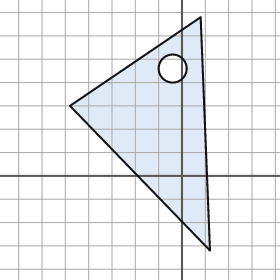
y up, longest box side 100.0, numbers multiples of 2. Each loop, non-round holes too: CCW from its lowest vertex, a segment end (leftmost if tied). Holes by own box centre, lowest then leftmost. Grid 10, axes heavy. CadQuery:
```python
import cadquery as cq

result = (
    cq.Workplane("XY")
    .moveTo(12.0, -32.0)
    .lineTo(8.0, 68.0)
    .lineTo(-48.0, 30.0)
    .close()
    .moveTo(-4.0, 46.0)
    .circle(6.0)
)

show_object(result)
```